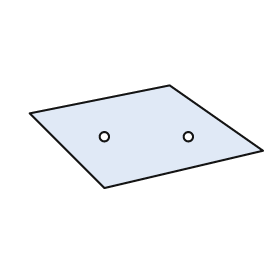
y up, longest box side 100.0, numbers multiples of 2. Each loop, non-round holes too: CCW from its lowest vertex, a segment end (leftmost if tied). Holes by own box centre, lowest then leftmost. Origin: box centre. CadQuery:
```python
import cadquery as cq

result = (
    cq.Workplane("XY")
    .moveTo(-18.0, -22.0)
    .lineTo(50.0, -6.0)
    .lineTo(10.0, 22.0)
    .lineTo(-50.0, 10.0)
    .close()
    .moveTo(-18.0, 0.0)
    .circle(2.0)
    .moveTo(18.0, 0.0)
    .circle(2.0)
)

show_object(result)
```